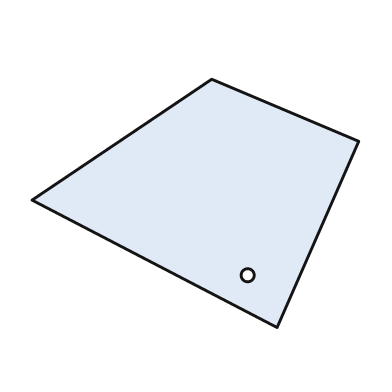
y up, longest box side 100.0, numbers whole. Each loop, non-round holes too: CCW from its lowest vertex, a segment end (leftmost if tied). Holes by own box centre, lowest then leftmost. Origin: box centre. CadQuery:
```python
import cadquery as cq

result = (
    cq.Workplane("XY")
    .moveTo(25.0, -38.0)
    .lineTo(50.0, 19.0)
    .lineTo(5.0, 38.0)
    .lineTo(-50.0, 1.0)
    .close()
    .moveTo(16.0, -22.0)
    .circle(2.0)
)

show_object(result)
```